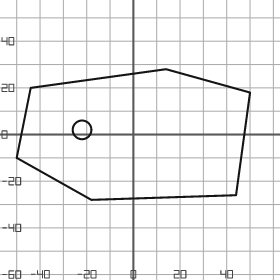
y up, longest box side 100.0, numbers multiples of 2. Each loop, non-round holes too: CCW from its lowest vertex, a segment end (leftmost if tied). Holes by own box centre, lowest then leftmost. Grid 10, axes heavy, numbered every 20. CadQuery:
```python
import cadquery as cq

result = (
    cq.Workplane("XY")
    .moveTo(-18.0, -28.0)
    .lineTo(44.0, -26.0)
    .lineTo(50.0, 18.0)
    .lineTo(14.0, 28.0)
    .lineTo(-44.0, 20.0)
    .lineTo(-50.0, -10.0)
    .close()
    .moveTo(-22.0, 2.0)
    .circle(4.0)
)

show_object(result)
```